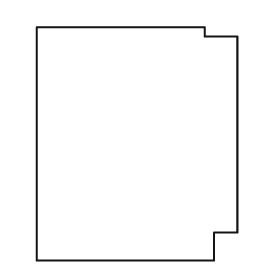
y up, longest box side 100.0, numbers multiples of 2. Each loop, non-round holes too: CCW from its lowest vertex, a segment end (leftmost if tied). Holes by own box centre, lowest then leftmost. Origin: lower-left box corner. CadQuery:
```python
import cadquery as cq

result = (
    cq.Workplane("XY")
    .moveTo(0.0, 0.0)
    .lineTo(76.0, 0.0)
    .lineTo(76.0, 12.0)
    .lineTo(86.0, 12.0)
    .lineTo(86.0, 96.0)
    .lineTo(72.0, 96.0)
    .lineTo(72.0, 100.0)
    .lineTo(0.0, 100.0)
    .close()
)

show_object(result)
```